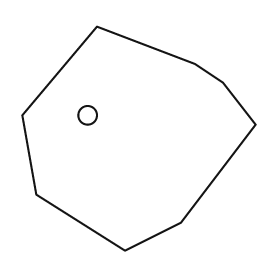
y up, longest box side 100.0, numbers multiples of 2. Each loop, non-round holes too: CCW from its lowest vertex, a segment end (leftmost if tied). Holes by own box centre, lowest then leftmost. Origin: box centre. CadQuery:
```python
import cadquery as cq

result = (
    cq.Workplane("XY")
    .moveTo(-6.0, -48.0)
    .lineTo(18.0, -36.0)
    .lineTo(50.0, 6.0)
    .lineTo(36.0, 24.0)
    .lineTo(24.0, 32.0)
    .lineTo(-18.0, 48.0)
    .lineTo(-50.0, 10.0)
    .lineTo(-44.0, -24.0)
    .close()
    .moveTo(-22.0, 10.0)
    .circle(4.0)
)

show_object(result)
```